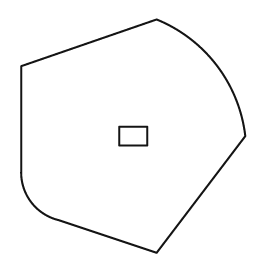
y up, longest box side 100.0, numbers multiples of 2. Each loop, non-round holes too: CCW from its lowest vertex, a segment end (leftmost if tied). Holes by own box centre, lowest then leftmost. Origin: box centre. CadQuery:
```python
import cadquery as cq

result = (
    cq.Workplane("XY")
    .moveTo(10.0, -50.0)
    .lineTo(48.0, 0.0)
    .threePointArc((36.0, 30.0), (10.0, 50.0))
    .lineTo(-48.0, 30.0)
    .lineTo(-48.0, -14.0)
    .threePointArc((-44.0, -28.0), (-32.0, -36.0))
    .close()
    .moveTo(-6.0, -4.0)
    .lineTo(6.0, -4.0)
    .lineTo(6.0, 4.0)
    .lineTo(-6.0, 4.0)
    .close()
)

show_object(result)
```